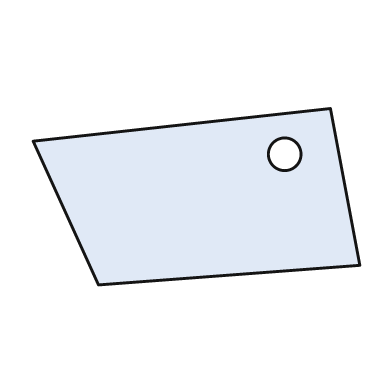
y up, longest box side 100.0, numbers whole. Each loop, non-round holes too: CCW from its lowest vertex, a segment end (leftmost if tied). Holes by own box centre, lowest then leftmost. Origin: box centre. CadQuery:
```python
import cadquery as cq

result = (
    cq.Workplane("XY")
    .moveTo(-30.0, -27.0)
    .lineTo(50.0, -21.0)
    .lineTo(41.0, 27.0)
    .lineTo(-50.0, 17.0)
    .close()
    .moveTo(27.0, 13.0)
    .circle(5.0)
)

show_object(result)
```